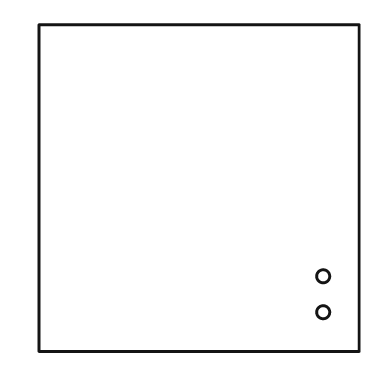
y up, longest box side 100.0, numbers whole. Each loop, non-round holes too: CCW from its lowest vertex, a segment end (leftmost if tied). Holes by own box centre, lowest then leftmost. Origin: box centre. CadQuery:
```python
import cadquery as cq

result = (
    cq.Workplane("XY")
    .moveTo(-49.0, -50.0)
    .lineTo(49.0, -50.0)
    .lineTo(49.0, 50.0)
    .lineTo(-49.0, 50.0)
    .close()
    .moveTo(38.0, -38.0)
    .circle(2.0)
    .moveTo(38.0, -27.0)
    .circle(2.0)
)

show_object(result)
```